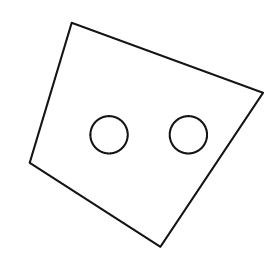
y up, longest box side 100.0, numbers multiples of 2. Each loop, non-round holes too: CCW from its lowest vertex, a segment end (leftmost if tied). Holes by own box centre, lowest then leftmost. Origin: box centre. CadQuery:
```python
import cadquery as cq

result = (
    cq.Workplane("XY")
    .moveTo(6.0, -48.0)
    .lineTo(50.0, 18.0)
    .lineTo(-32.0, 48.0)
    .lineTo(-50.0, -12.0)
    .close()
    .moveTo(-16.0, 0.0)
    .circle(8.0)
    .moveTo(18.0, 0.0)
    .circle(8.0)
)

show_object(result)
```